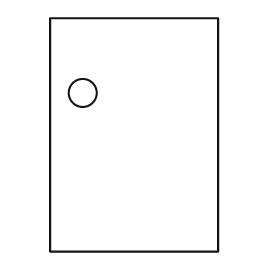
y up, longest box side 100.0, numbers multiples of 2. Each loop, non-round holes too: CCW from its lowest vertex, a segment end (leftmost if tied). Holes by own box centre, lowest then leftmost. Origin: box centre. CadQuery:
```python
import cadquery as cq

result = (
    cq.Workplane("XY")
    .moveTo(-36.0, -50.0)
    .lineTo(36.0, -50.0)
    .lineTo(36.0, 50.0)
    .lineTo(-36.0, 50.0)
    .close()
    .moveTo(-22.0, 18.0)
    .circle(6.0)
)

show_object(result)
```